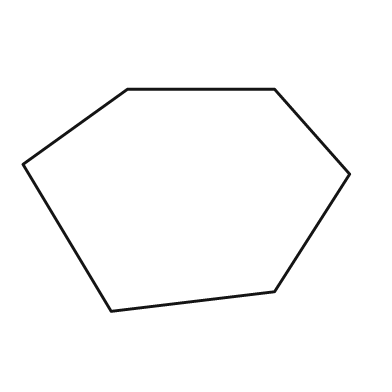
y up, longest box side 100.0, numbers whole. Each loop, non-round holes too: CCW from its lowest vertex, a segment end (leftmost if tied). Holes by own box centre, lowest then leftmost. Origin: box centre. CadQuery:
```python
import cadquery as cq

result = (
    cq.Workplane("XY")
    .moveTo(-23.0, -34.0)
    .lineTo(27.0, -28.0)
    .lineTo(50.0, 8.0)
    .lineTo(27.0, 34.0)
    .lineTo(-18.0, 34.0)
    .lineTo(-50.0, 11.0)
    .close()
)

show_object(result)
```